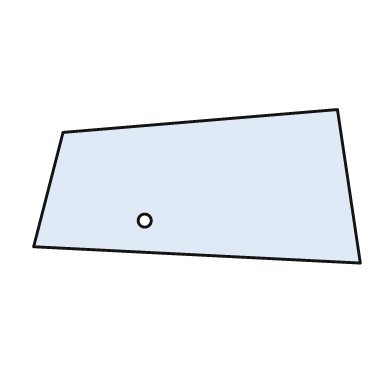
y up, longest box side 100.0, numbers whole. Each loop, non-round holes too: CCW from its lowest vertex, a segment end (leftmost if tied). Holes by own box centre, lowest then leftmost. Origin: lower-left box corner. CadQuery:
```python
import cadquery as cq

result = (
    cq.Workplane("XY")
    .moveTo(100.0, 0.0)
    .lineTo(93.0, 47.0)
    .lineTo(9.0, 40.0)
    .lineTo(0.0, 5.0)
    .close()
    .moveTo(34.0, 13.0)
    .circle(2.0)
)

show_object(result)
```